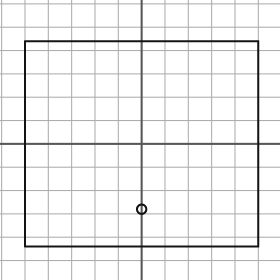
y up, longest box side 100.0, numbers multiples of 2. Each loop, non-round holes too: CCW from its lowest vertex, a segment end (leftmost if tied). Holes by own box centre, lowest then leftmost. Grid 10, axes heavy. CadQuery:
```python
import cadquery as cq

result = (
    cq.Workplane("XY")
    .moveTo(-50.0, -44.0)
    .lineTo(50.0, -44.0)
    .lineTo(50.0, 44.0)
    .lineTo(-50.0, 44.0)
    .close()
    .moveTo(0.0, -28.0)
    .circle(2.0)
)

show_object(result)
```